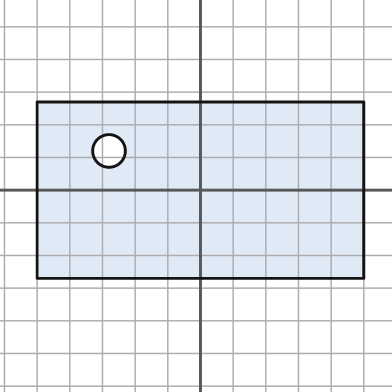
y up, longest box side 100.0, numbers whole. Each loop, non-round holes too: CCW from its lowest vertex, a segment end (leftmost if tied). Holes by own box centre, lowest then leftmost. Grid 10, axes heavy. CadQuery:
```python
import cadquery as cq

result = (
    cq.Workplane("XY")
    .moveTo(-50.0, -27.0)
    .lineTo(50.0, -27.0)
    .lineTo(50.0, 27.0)
    .lineTo(-50.0, 27.0)
    .close()
    .moveTo(-28.0, 12.0)
    .circle(5.0)
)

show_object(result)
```